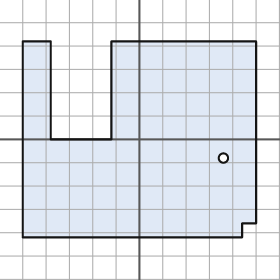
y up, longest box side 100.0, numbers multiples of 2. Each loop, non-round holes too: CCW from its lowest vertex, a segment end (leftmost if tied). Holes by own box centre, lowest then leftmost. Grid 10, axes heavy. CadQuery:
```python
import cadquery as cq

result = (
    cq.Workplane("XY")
    .moveTo(-50.0, -42.0)
    .lineTo(44.0, -42.0)
    .lineTo(44.0, -36.0)
    .lineTo(50.0, -36.0)
    .lineTo(50.0, 42.0)
    .lineTo(-12.0, 42.0)
    .lineTo(-12.0, 0.0)
    .lineTo(-38.0, 0.0)
    .lineTo(-38.0, 42.0)
    .lineTo(-50.0, 42.0)
    .close()
    .moveTo(36.0, -8.0)
    .circle(2.0)
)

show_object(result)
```